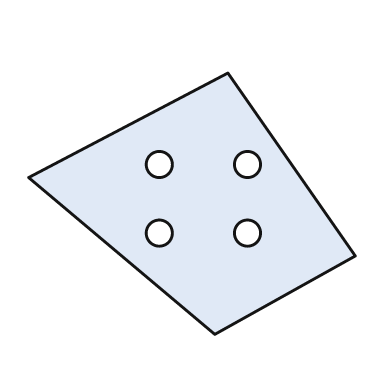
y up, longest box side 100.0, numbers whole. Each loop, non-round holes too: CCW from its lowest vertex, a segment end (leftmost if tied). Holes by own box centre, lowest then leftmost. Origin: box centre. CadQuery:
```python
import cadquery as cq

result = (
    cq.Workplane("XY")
    .moveTo(7.0, -40.0)
    .lineTo(50.0, -16.0)
    .lineTo(11.0, 40.0)
    .lineTo(-50.0, 8.0)
    .close()
    .moveTo(-10.0, -9.0)
    .circle(4.0)
    .moveTo(17.0, -9.0)
    .circle(4.0)
    .moveTo(-10.0, 12.0)
    .circle(4.0)
    .moveTo(17.0, 12.0)
    .circle(4.0)
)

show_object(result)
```